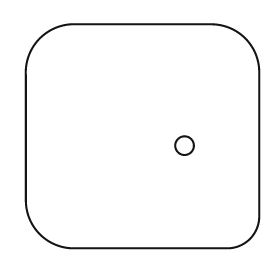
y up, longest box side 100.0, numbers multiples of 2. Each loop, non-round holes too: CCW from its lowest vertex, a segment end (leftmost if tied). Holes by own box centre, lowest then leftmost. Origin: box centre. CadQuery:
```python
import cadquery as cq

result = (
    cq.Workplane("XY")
    .moveTo(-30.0, -48.0)
    .lineTo(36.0, -48.0)
    .threePointArc((46.0, -44.0), (50.0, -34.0))
    .lineTo(50.0, 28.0)
    .threePointArc((44.0, 42.0), (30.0, 48.0))
    .lineTo(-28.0, 48.0)
    .threePointArc((-44.0, 42.0), (-50.0, 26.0))
    .lineTo(-50.0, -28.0)
    .threePointArc((-44.0, -42.0), (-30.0, -48.0))
    .close()
    .moveTo(18.0, -4.0)
    .circle(4.0)
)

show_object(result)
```